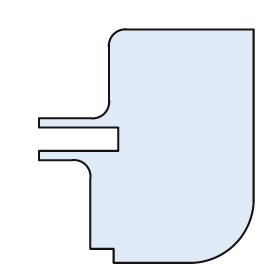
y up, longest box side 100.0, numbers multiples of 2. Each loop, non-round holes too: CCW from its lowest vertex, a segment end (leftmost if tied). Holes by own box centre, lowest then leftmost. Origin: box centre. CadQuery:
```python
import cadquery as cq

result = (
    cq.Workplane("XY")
    .moveTo(-14.0, -50.0)
    .lineTo(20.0, -50.0)
    .threePointArc((38.0, -42.0), (46.0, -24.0))
    .lineTo(46.0, 50.0)
    .lineTo(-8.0, 50.0)
    .threePointArc((-14.0, 48.0), (-16.0, 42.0))
    .lineTo(-16.0, 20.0)
    .threePointArc((-18.0, 14.0), (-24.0, 12.0))
    .lineTo(-46.0, 12.0)
    .lineTo(-46.0, 8.0)
    .lineTo(-12.0, 8.0)
    .lineTo(-12.0, -2.0)
    .lineTo(-46.0, -2.0)
    .lineTo(-46.0, -6.0)
    .lineTo(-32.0, -6.0)
    .threePointArc((-26.0, -8.0), (-24.0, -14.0))
    .lineTo(-24.0, -44.0)
    .lineTo(-14.0, -44.0)
    .close()
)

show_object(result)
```